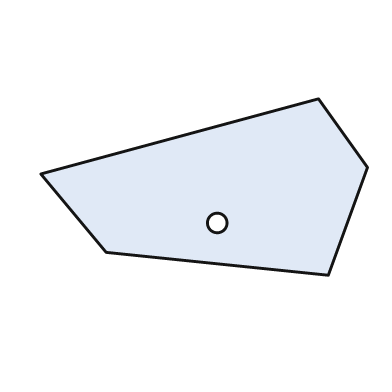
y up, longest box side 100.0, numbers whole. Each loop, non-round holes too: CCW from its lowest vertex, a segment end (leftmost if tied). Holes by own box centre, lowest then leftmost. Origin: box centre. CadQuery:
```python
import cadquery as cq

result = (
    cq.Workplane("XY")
    .moveTo(38.0, -27.0)
    .lineTo(50.0, 6.0)
    .lineTo(35.0, 27.0)
    .lineTo(-50.0, 4.0)
    .lineTo(-30.0, -20.0)
    .close()
    .moveTo(4.0, -11.0)
    .circle(3.0)
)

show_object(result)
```